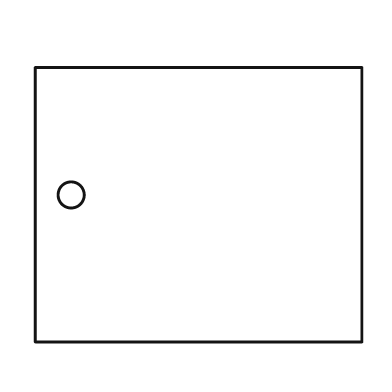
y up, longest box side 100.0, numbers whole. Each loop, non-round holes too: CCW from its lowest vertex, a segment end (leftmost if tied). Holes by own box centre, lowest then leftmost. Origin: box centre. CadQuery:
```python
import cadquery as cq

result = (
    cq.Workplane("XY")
    .moveTo(-50.0, -42.0)
    .lineTo(50.0, -42.0)
    .lineTo(50.0, 42.0)
    .lineTo(-50.0, 42.0)
    .close()
    .moveTo(-39.0, 3.0)
    .circle(4.0)
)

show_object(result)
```